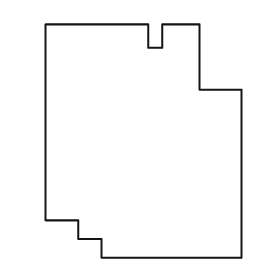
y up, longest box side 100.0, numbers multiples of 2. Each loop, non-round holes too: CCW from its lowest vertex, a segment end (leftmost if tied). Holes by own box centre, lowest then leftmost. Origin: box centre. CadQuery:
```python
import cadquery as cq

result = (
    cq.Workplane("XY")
    .moveTo(-18.0, -50.0)
    .lineTo(42.0, -50.0)
    .lineTo(42.0, 22.0)
    .lineTo(24.0, 22.0)
    .lineTo(24.0, 50.0)
    .lineTo(8.0, 50.0)
    .lineTo(8.0, 40.0)
    .lineTo(2.0, 40.0)
    .lineTo(2.0, 50.0)
    .lineTo(-42.0, 50.0)
    .lineTo(-42.0, -34.0)
    .lineTo(-28.0, -34.0)
    .lineTo(-28.0, -42.0)
    .lineTo(-18.0, -42.0)
    .close()
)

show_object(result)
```